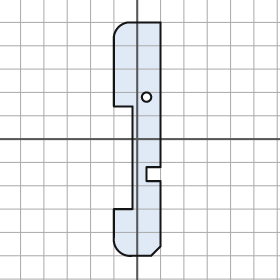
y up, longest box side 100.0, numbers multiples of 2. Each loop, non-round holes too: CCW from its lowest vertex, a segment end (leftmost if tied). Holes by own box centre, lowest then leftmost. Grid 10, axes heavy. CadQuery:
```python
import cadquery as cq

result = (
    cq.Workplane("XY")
    .moveTo(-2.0, -50.0)
    .lineTo(6.0, -50.0)
    .lineTo(10.0, -46.0)
    .lineTo(10.0, -18.0)
    .lineTo(4.0, -18.0)
    .lineTo(4.0, -12.0)
    .lineTo(10.0, -12.0)
    .lineTo(10.0, 50.0)
    .lineTo(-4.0, 50.0)
    .threePointArc((-8.0, 48.0), (-10.0, 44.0))
    .lineTo(-10.0, 14.0)
    .lineTo(-2.0, 14.0)
    .lineTo(-2.0, -30.0)
    .lineTo(-10.0, -30.0)
    .lineTo(-10.0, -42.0)
    .threePointArc((-8.0, -48.0), (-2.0, -50.0))
    .close()
    .moveTo(4.0, 18.0)
    .circle(2.0)
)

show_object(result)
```